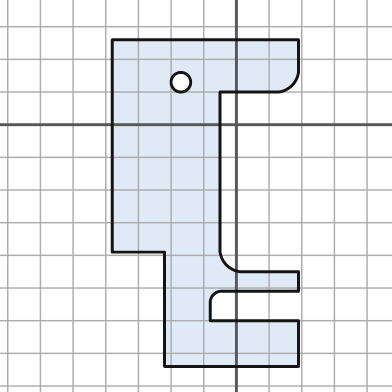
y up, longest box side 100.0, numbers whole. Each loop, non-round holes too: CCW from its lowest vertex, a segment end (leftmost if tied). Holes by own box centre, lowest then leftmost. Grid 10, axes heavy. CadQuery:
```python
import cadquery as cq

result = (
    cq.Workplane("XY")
    .moveTo(-22.0, -74.0)
    .lineTo(19.0, -74.0)
    .lineTo(19.0, -60.0)
    .lineTo(-8.0, -60.0)
    .lineTo(-8.0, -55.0)
    .threePointArc((-7.0, -52.0), (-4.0, -51.0))
    .lineTo(19.0, -51.0)
    .lineTo(19.0, -45.0)
    .lineTo(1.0, -45.0)
    .threePointArc((-3.0, -43.0), (-5.0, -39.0))
    .lineTo(-5.0, 10.0)
    .lineTo(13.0, 10.0)
    .threePointArc((17.0, 12.0), (19.0, 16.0))
    .lineTo(19.0, 26.0)
    .lineTo(-38.0, 26.0)
    .lineTo(-38.0, -39.0)
    .lineTo(-22.0, -39.0)
    .close()
    .moveTo(-17.0, 13.0)
    .circle(3.0)
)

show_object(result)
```